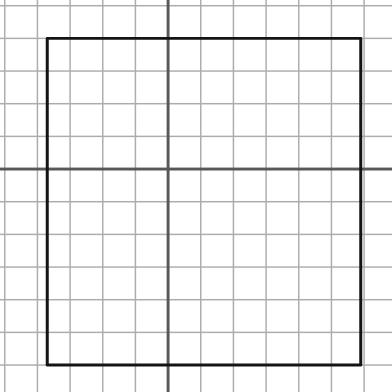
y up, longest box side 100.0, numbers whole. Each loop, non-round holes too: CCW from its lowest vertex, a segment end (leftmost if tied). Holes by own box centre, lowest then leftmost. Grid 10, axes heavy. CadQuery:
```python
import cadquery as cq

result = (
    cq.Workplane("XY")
    .moveTo(-37.0, -60.0)
    .lineTo(59.0, -60.0)
    .lineTo(59.0, 40.0)
    .lineTo(-37.0, 40.0)
    .close()
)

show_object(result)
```